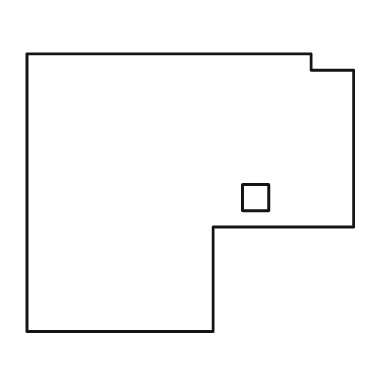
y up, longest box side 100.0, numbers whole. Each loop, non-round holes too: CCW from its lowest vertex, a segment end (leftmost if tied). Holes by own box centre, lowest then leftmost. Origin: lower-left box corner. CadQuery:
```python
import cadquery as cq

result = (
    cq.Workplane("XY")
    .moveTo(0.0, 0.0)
    .lineTo(57.0, 0.0)
    .lineTo(57.0, 32.0)
    .lineTo(100.0, 32.0)
    .lineTo(100.0, 80.0)
    .lineTo(87.0, 80.0)
    .lineTo(87.0, 85.0)
    .lineTo(0.0, 85.0)
    .close()
    .moveTo(66.0, 37.0)
    .lineTo(74.0, 37.0)
    .lineTo(74.0, 45.0)
    .lineTo(66.0, 45.0)
    .close()
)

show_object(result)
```